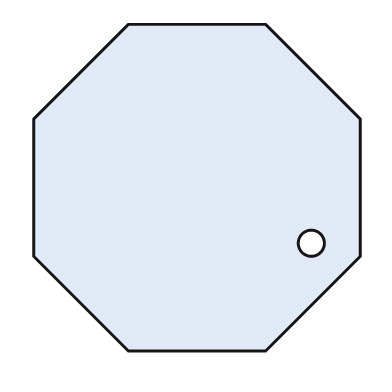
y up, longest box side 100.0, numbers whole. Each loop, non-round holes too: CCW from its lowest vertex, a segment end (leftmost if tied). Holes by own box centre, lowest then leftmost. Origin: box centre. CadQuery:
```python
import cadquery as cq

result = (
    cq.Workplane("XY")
    .moveTo(-21.0, -50.0)
    .lineTo(21.0, -50.0)
    .lineTo(50.0, -21.0)
    .lineTo(50.0, 21.0)
    .lineTo(21.0, 50.0)
    .lineTo(-21.0, 50.0)
    .lineTo(-50.0, 21.0)
    .lineTo(-50.0, -21.0)
    .close()
    .moveTo(35.0, -17.0)
    .circle(4.0)
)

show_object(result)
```